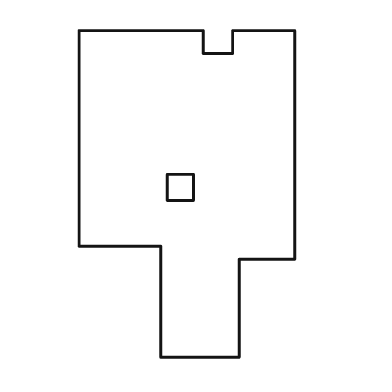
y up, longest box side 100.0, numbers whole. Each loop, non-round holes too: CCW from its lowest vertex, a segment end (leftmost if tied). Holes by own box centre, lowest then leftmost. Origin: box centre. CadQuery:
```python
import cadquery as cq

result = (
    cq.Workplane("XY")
    .moveTo(-8.0, -50.0)
    .lineTo(16.0, -50.0)
    .lineTo(16.0, -20.0)
    .lineTo(33.0, -20.0)
    .lineTo(33.0, 50.0)
    .lineTo(14.0, 50.0)
    .lineTo(14.0, 43.0)
    .lineTo(5.0, 43.0)
    .lineTo(5.0, 50.0)
    .lineTo(-33.0, 50.0)
    .lineTo(-33.0, -16.0)
    .lineTo(-8.0, -16.0)
    .close()
    .moveTo(-6.0, -2.0)
    .lineTo(2.0, -2.0)
    .lineTo(2.0, 6.0)
    .lineTo(-6.0, 6.0)
    .close()
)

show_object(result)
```